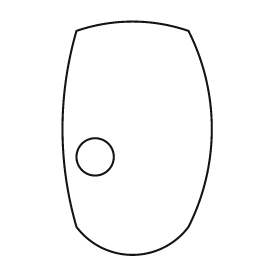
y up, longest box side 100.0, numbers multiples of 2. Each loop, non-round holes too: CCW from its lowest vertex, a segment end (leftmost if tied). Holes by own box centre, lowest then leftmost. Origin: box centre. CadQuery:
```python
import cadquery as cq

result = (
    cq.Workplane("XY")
    .moveTo(-26.0, -38.0)
    .threePointArc((-2.0, -50.0), (22.0, -38.0))
    .threePointArc((32.0, 4.0), (22.0, 46.0))
    .threePointArc((-2.0, 50.0), (-26.0, 46.0))
    .threePointArc((-32.0, 4.0), (-26.0, -38.0))
    .close()
    .moveTo(-18.0, -8.0)
    .circle(8.0)
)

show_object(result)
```